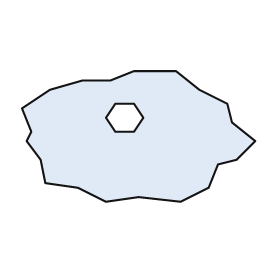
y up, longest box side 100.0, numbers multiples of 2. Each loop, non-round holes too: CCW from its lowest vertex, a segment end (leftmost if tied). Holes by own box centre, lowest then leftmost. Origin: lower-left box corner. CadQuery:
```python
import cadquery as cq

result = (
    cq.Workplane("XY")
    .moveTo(36.0, 0.0)
    .lineTo(50.0, 2.0)
    .lineTo(68.0, 0.0)
    .lineTo(80.0, 6.0)
    .lineTo(84.0, 16.0)
    .lineTo(92.0, 18.0)
    .lineTo(100.0, 26.0)
    .lineTo(90.0, 34.0)
    .lineTo(88.0, 42.0)
    .lineTo(76.0, 48.0)
    .lineTo(66.0, 56.0)
    .lineTo(48.0, 56.0)
    .lineTo(38.0, 52.0)
    .lineTo(26.0, 52.0)
    .lineTo(12.0, 48.0)
    .lineTo(0.0, 40.0)
    .lineTo(4.0, 30.0)
    .lineTo(2.0, 26.0)
    .lineTo(8.0, 18.0)
    .lineTo(10.0, 8.0)
    .lineTo(24.0, 6.0)
    .close()
    .moveTo(40.0, 30.0)
    .lineTo(48.0, 30.0)
    .lineTo(52.0, 36.0)
    .lineTo(48.0, 42.0)
    .lineTo(40.0, 42.0)
    .lineTo(36.0, 36.0)
    .close()
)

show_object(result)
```